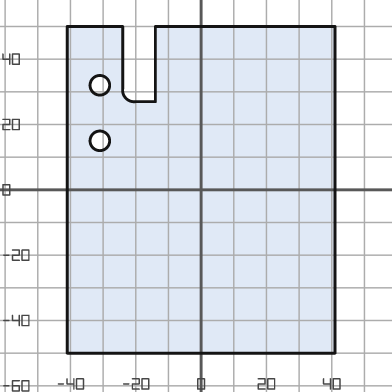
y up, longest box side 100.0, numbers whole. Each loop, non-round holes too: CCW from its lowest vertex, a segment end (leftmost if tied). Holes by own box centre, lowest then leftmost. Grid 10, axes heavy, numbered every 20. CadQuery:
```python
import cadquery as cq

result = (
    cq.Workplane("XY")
    .moveTo(-41.0, -50.0)
    .lineTo(41.0, -50.0)
    .lineTo(41.0, 50.0)
    .lineTo(-14.0, 50.0)
    .lineTo(-14.0, 27.0)
    .lineTo(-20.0, 27.0)
    .threePointArc((-23.0, 28.0), (-24.0, 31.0))
    .lineTo(-24.0, 50.0)
    .lineTo(-41.0, 50.0)
    .close()
    .moveTo(-31.0, 15.0)
    .circle(3.0)
    .moveTo(-31.0, 32.0)
    .circle(3.0)
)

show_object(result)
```